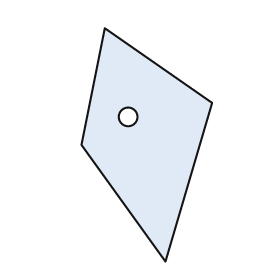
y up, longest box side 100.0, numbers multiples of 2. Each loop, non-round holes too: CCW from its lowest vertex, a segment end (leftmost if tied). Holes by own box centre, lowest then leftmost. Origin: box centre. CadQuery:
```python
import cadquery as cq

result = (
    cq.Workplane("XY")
    .moveTo(8.0, -50.0)
    .lineTo(28.0, 18.0)
    .lineTo(-18.0, 50.0)
    .lineTo(-28.0, 0.0)
    .close()
    .moveTo(-8.0, 12.0)
    .circle(4.0)
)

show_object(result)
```